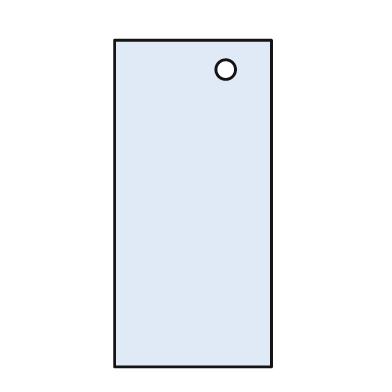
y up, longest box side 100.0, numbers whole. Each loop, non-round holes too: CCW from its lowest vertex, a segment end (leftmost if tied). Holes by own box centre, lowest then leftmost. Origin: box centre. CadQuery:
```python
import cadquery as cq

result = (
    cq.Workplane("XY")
    .moveTo(-24.0, -50.0)
    .lineTo(24.0, -50.0)
    .lineTo(24.0, 50.0)
    .lineTo(-24.0, 50.0)
    .close()
    .moveTo(10.0, 41.0)
    .circle(3.0)
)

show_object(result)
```